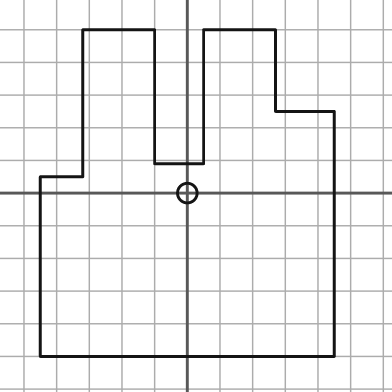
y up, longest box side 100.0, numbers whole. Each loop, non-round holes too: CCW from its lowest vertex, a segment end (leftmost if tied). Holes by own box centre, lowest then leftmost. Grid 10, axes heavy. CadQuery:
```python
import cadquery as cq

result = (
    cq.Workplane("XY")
    .moveTo(-45.0, -50.0)
    .lineTo(45.0, -50.0)
    .lineTo(45.0, 25.0)
    .lineTo(27.0, 25.0)
    .lineTo(27.0, 50.0)
    .lineTo(5.0, 50.0)
    .lineTo(5.0, 9.0)
    .lineTo(-10.0, 9.0)
    .lineTo(-10.0, 50.0)
    .lineTo(-32.0, 50.0)
    .lineTo(-32.0, 5.0)
    .lineTo(-45.0, 5.0)
    .close()
    .moveTo(0.0, 0.0)
    .circle(3.0)
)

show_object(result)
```